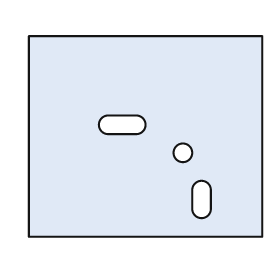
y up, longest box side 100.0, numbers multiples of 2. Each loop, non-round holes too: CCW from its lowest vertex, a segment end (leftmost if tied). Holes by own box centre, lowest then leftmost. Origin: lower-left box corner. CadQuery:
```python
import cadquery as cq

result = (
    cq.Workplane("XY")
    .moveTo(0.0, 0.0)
    .lineTo(100.0, 0.0)
    .lineTo(100.0, 86.0)
    .lineTo(0.0, 86.0)
    .close()
    .moveTo(70.0, 12.0)
    .threePointArc((74.0, 8.0), (78.0, 12.0))
    .lineTo(78.0, 20.0)
    .threePointArc((74.0, 24.0), (70.0, 20.0))
    .close()
    .moveTo(66.0, 36.0)
    .circle(4.0)
    .moveTo(34.0, 44.0)
    .lineTo(46.0, 44.0)
    .threePointArc((50.0, 48.0), (46.0, 52.0))
    .lineTo(34.0, 52.0)
    .threePointArc((30.0, 48.0), (34.0, 44.0))
    .close()
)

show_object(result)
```